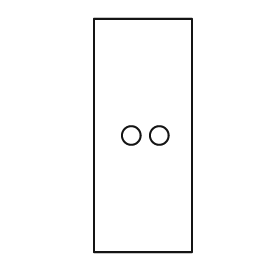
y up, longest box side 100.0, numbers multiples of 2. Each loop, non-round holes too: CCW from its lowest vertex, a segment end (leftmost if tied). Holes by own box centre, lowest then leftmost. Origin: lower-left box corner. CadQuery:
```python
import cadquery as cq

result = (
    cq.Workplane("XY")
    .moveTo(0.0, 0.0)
    .lineTo(42.0, 0.0)
    .lineTo(42.0, 100.0)
    .lineTo(0.0, 100.0)
    .close()
    .moveTo(16.0, 50.0)
    .circle(4.0)
    .moveTo(28.0, 50.0)
    .circle(4.0)
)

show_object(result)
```